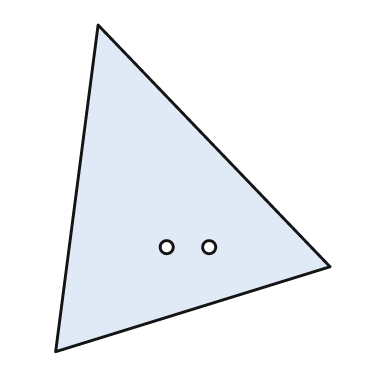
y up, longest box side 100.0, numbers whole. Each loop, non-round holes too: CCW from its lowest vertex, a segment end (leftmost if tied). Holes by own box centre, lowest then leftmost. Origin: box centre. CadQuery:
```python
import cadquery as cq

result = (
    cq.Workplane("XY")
    .moveTo(-42.0, -50.0)
    .lineTo(42.0, -24.0)
    .lineTo(-29.0, 50.0)
    .close()
    .moveTo(-8.0, -18.0)
    .circle(2.0)
    .moveTo(5.0, -18.0)
    .circle(2.0)
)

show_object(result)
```